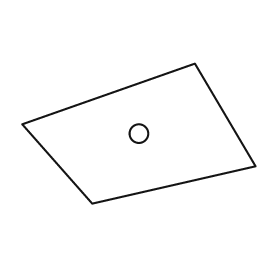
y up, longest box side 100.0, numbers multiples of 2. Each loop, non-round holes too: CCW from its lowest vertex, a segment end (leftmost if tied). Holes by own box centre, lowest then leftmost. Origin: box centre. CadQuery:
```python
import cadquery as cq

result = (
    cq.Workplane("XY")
    .moveTo(-20.0, -30.0)
    .lineTo(50.0, -14.0)
    .lineTo(24.0, 30.0)
    .lineTo(-50.0, 4.0)
    .close()
    .moveTo(0.0, 0.0)
    .circle(4.0)
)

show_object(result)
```